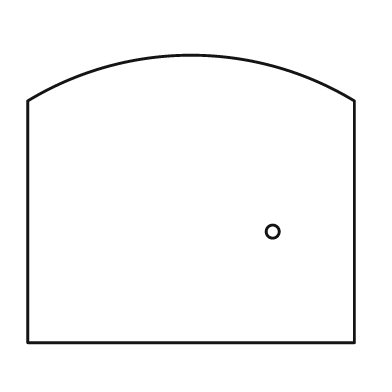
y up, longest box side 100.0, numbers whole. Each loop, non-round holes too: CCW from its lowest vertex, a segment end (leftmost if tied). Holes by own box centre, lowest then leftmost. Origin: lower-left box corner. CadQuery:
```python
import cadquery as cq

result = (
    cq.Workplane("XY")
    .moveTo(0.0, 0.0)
    .lineTo(100.0, 0.0)
    .lineTo(100.0, 74.0)
    .threePointArc((50.0, 88.0), (0.0, 74.0))
    .close()
    .moveTo(75.0, 34.0)
    .circle(2.0)
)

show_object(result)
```